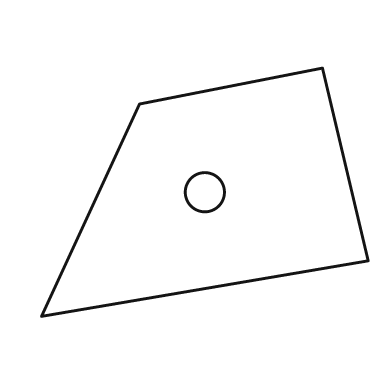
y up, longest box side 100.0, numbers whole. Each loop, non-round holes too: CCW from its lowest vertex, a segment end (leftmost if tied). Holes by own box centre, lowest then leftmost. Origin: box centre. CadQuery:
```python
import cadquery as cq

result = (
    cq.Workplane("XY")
    .moveTo(-50.0, -38.0)
    .lineTo(50.0, -21.0)
    .lineTo(36.0, 38.0)
    .lineTo(-20.0, 27.0)
    .close()
    .moveTo(0.0, 0.0)
    .circle(6.0)
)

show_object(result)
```